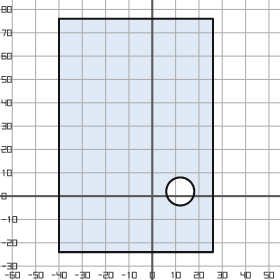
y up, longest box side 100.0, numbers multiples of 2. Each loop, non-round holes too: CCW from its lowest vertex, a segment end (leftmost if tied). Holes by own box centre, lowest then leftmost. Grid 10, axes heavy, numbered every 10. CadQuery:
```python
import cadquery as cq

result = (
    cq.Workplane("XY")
    .moveTo(-40.0, -24.0)
    .lineTo(26.0, -24.0)
    .lineTo(26.0, 76.0)
    .lineTo(-40.0, 76.0)
    .close()
    .moveTo(12.0, 2.0)
    .circle(6.0)
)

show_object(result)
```